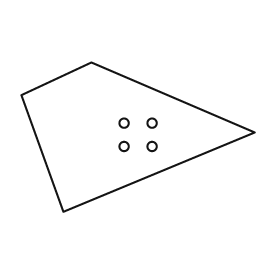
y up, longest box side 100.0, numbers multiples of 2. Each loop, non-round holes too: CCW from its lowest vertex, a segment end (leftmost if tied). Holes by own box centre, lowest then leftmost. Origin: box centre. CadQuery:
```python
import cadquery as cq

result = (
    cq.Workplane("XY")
    .moveTo(-32.0, -32.0)
    .lineTo(50.0, 2.0)
    .lineTo(-20.0, 32.0)
    .lineTo(-50.0, 18.0)
    .close()
    .moveTo(-6.0, -4.0)
    .circle(2.0)
    .moveTo(6.0, -4.0)
    .circle(2.0)
    .moveTo(-6.0, 6.0)
    .circle(2.0)
    .moveTo(6.0, 6.0)
    .circle(2.0)
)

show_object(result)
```